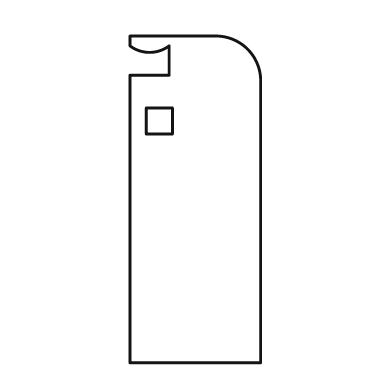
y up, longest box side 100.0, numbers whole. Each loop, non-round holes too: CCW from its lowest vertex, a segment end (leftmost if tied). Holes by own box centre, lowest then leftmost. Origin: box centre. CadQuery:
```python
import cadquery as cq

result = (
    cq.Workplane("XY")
    .moveTo(-20.0, -50.0)
    .lineTo(20.0, -50.0)
    .lineTo(20.0, 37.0)
    .threePointArc((16.0, 46.0), (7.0, 50.0))
    .lineTo(-20.0, 50.0)
    .lineTo(-20.0, 47.0)
    .threePointArc((-14.0, 45.0), (-8.0, 47.0))
    .lineTo(-8.0, 38.0)
    .lineTo(-20.0, 38.0)
    .close()
    .moveTo(-15.0, 20.0)
    .lineTo(-7.0, 20.0)
    .lineTo(-7.0, 28.0)
    .lineTo(-15.0, 28.0)
    .close()
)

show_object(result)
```